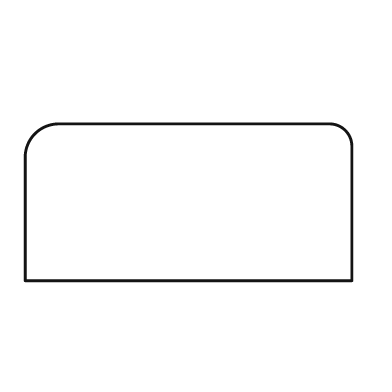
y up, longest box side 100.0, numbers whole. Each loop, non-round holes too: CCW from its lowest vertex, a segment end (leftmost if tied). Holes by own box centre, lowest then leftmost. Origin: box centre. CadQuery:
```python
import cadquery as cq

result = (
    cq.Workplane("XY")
    .moveTo(-50.0, -24.0)
    .lineTo(50.0, -24.0)
    .lineTo(50.0, 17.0)
    .threePointArc((48.0, 22.0), (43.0, 24.0))
    .lineTo(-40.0, 24.0)
    .threePointArc((-47.0, 21.0), (-50.0, 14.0))
    .close()
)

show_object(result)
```